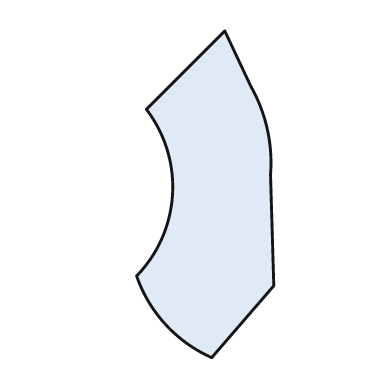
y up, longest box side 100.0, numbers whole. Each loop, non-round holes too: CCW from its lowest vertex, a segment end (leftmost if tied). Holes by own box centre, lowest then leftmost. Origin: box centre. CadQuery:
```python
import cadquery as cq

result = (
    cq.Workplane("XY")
    .moveTo(2.0, -50.0)
    .lineTo(21.0, -28.0)
    .lineTo(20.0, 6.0)
    .threePointArc((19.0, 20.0), (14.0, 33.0))
    .lineTo(6.0, 50.0)
    .lineTo(-18.0, 26.0)
    .threePointArc((-10.0, 0.0), (-21.0, -25.0))
    .threePointArc((-12.0, -40.0), (2.0, -50.0))
    .close()
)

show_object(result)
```